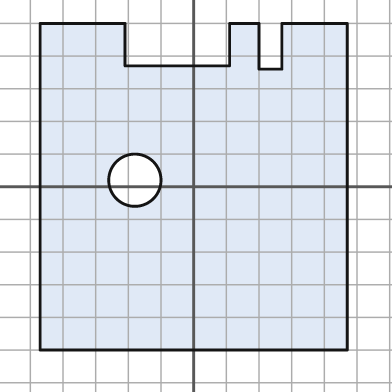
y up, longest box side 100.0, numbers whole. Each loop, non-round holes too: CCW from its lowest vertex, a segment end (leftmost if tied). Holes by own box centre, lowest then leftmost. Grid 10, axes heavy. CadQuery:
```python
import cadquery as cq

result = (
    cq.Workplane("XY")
    .moveTo(-47.0, -50.0)
    .lineTo(47.0, -50.0)
    .lineTo(47.0, 50.0)
    .lineTo(27.0, 50.0)
    .lineTo(27.0, 36.0)
    .lineTo(20.0, 36.0)
    .lineTo(20.0, 50.0)
    .lineTo(11.0, 50.0)
    .lineTo(11.0, 37.0)
    .lineTo(-21.0, 37.0)
    .lineTo(-21.0, 50.0)
    .lineTo(-47.0, 50.0)
    .close()
    .moveTo(-18.0, 2.0)
    .circle(8.0)
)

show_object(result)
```